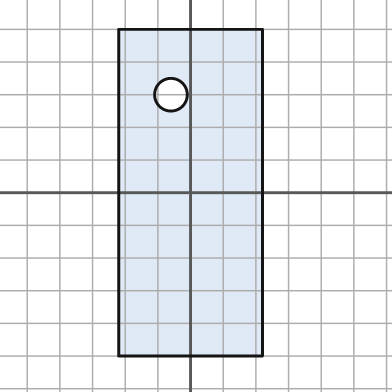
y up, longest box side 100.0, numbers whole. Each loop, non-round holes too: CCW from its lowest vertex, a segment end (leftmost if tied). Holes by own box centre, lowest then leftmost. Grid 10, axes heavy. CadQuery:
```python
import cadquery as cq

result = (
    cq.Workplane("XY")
    .moveTo(-22.0, -50.0)
    .lineTo(22.0, -50.0)
    .lineTo(22.0, 50.0)
    .lineTo(-22.0, 50.0)
    .close()
    .moveTo(-6.0, 30.0)
    .circle(5.0)
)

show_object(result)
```